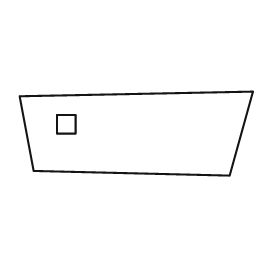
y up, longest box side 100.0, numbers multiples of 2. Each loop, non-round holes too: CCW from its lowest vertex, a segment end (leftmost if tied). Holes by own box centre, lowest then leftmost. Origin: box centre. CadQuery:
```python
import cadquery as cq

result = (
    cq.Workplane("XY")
    .moveTo(40.0, -18.0)
    .lineTo(50.0, 18.0)
    .lineTo(-50.0, 16.0)
    .lineTo(-44.0, -16.0)
    .close()
    .moveTo(-34.0, 0.0)
    .lineTo(-26.0, 0.0)
    .lineTo(-26.0, 8.0)
    .lineTo(-34.0, 8.0)
    .close()
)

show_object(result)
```